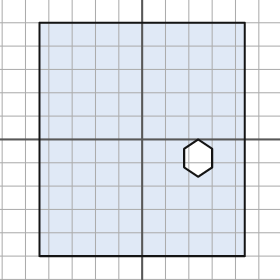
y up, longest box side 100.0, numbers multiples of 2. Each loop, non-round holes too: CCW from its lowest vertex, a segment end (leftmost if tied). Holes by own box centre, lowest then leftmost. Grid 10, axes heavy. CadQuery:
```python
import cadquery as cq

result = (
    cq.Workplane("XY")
    .moveTo(-44.0, -50.0)
    .lineTo(44.0, -50.0)
    .lineTo(44.0, 50.0)
    .lineTo(-44.0, 50.0)
    .close()
    .moveTo(24.0, -16.0)
    .lineTo(30.0, -12.0)
    .lineTo(30.0, -4.0)
    .lineTo(24.0, 0.0)
    .lineTo(18.0, -4.0)
    .lineTo(18.0, -12.0)
    .close()
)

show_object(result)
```